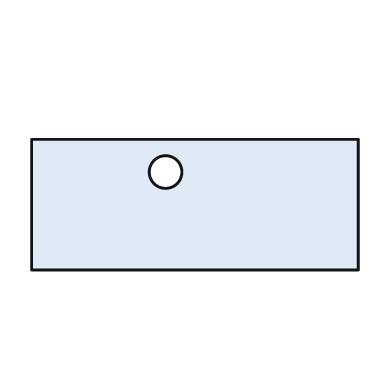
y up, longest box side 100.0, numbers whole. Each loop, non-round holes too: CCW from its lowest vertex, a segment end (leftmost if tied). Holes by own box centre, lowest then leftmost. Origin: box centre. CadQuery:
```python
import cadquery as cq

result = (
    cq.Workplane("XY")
    .moveTo(-50.0, -20.0)
    .lineTo(50.0, -20.0)
    .lineTo(50.0, 20.0)
    .lineTo(-50.0, 20.0)
    .close()
    .moveTo(-9.0, 10.0)
    .circle(5.0)
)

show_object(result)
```